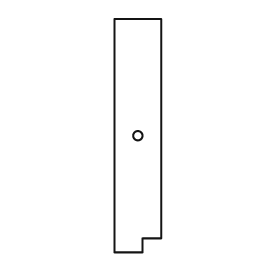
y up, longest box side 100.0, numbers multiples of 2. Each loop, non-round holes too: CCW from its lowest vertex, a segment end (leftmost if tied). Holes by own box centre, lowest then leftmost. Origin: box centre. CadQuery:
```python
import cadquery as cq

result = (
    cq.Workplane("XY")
    .moveTo(-10.0, -50.0)
    .lineTo(2.0, -50.0)
    .lineTo(2.0, -44.0)
    .lineTo(10.0, -44.0)
    .lineTo(10.0, 50.0)
    .lineTo(-10.0, 50.0)
    .close()
    .moveTo(0.0, 0.0)
    .circle(2.0)
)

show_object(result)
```